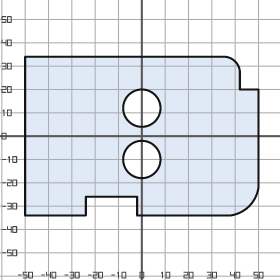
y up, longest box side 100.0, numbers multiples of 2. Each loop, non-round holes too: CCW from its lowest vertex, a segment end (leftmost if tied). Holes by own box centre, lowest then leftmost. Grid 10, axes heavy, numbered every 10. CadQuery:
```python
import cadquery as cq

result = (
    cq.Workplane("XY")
    .moveTo(-50.0, -34.0)
    .lineTo(-24.0, -34.0)
    .lineTo(-24.0, -26.0)
    .lineTo(-2.0, -26.0)
    .lineTo(-2.0, -34.0)
    .lineTo(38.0, -34.0)
    .threePointArc((46.0, -30.0), (50.0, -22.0))
    .lineTo(50.0, 20.0)
    .lineTo(42.0, 20.0)
    .lineTo(42.0, 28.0)
    .threePointArc((40.0, 32.0), (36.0, 34.0))
    .lineTo(-50.0, 34.0)
    .close()
    .moveTo(0.0, -10.0)
    .circle(8.0)
    .moveTo(0.0, 12.0)
    .circle(8.0)
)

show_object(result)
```